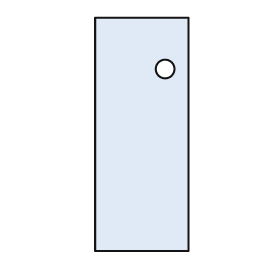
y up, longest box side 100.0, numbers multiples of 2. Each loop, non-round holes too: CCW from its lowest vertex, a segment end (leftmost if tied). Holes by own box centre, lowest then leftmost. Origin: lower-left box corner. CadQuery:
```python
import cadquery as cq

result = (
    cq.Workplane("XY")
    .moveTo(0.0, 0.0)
    .lineTo(40.0, 0.0)
    .lineTo(40.0, 100.0)
    .lineTo(0.0, 100.0)
    .close()
    .moveTo(30.0, 78.0)
    .circle(4.0)
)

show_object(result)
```